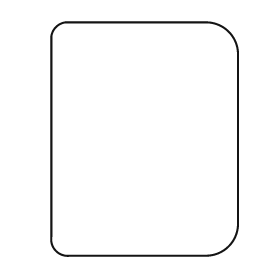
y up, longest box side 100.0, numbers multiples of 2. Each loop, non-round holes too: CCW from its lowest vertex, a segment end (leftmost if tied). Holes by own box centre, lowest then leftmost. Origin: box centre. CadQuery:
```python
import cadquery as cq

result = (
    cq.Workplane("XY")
    .moveTo(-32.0, -50.0)
    .lineTo(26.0, -50.0)
    .threePointArc((36.0, -46.0), (40.0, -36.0))
    .lineTo(40.0, 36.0)
    .threePointArc((36.0, 46.0), (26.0, 50.0))
    .lineTo(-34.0, 50.0)
    .threePointArc((-38.0, 48.0), (-40.0, 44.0))
    .lineTo(-40.0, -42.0)
    .threePointArc((-38.0, -48.0), (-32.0, -50.0))
    .close()
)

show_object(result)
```